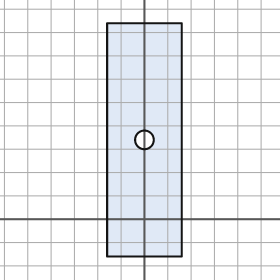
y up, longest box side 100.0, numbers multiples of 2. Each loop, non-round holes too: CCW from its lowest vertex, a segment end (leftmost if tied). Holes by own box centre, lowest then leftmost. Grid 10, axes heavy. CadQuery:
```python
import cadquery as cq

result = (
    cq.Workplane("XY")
    .moveTo(-16.0, -16.0)
    .lineTo(16.0, -16.0)
    .lineTo(16.0, 84.0)
    .lineTo(-16.0, 84.0)
    .close()
    .moveTo(0.0, 34.0)
    .circle(4.0)
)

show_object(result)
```